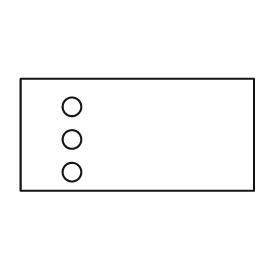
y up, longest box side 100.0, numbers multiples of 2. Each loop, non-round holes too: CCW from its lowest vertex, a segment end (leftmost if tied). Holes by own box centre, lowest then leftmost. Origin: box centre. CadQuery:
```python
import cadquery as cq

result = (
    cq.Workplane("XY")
    .moveTo(-50.0, -24.0)
    .lineTo(50.0, -24.0)
    .lineTo(50.0, 24.0)
    .lineTo(-50.0, 24.0)
    .close()
    .moveTo(-28.0, -16.0)
    .circle(4.0)
    .moveTo(-28.0, -2.0)
    .circle(4.0)
    .moveTo(-28.0, 12.0)
    .circle(4.0)
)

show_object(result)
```